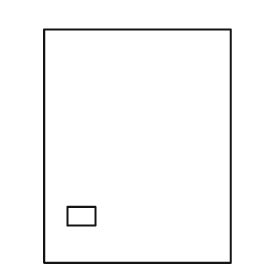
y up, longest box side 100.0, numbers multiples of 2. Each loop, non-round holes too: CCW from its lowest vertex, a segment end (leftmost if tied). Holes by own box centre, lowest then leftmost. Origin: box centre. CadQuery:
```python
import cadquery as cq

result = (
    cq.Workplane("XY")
    .moveTo(-40.0, -50.0)
    .lineTo(40.0, -50.0)
    .lineTo(40.0, 50.0)
    .lineTo(-40.0, 50.0)
    .close()
    .moveTo(-30.0, -34.0)
    .lineTo(-18.0, -34.0)
    .lineTo(-18.0, -26.0)
    .lineTo(-30.0, -26.0)
    .close()
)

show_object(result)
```